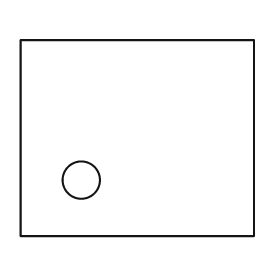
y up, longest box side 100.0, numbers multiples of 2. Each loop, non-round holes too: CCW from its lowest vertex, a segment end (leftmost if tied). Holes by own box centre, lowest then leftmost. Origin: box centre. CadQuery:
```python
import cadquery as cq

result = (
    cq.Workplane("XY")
    .moveTo(-50.0, -42.0)
    .lineTo(50.0, -42.0)
    .lineTo(50.0, 42.0)
    .lineTo(-50.0, 42.0)
    .close()
    .moveTo(-24.0, -18.0)
    .circle(8.0)
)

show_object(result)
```